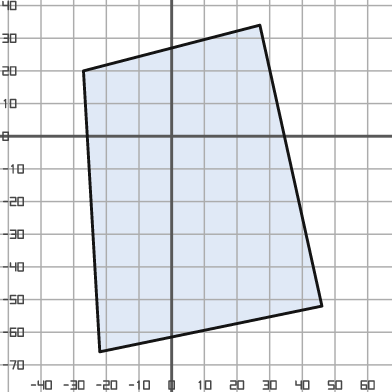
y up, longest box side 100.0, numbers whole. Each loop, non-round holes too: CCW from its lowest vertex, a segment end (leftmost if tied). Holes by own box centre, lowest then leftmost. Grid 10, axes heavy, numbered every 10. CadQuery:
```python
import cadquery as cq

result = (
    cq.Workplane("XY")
    .moveTo(-22.0, -66.0)
    .lineTo(46.0, -52.0)
    .lineTo(27.0, 34.0)
    .lineTo(-27.0, 20.0)
    .close()
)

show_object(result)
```